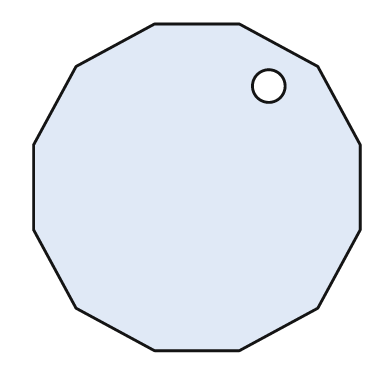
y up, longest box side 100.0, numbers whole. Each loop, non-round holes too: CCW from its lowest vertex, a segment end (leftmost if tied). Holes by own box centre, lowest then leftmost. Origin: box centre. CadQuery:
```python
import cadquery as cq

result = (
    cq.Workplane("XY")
    .moveTo(-13.0, -50.0)
    .lineTo(13.0, -50.0)
    .lineTo(37.0, -37.0)
    .lineTo(50.0, -13.0)
    .lineTo(50.0, 13.0)
    .lineTo(37.0, 37.0)
    .lineTo(13.0, 50.0)
    .lineTo(-13.0, 50.0)
    .lineTo(-37.0, 37.0)
    .lineTo(-50.0, 13.0)
    .lineTo(-50.0, -13.0)
    .lineTo(-37.0, -37.0)
    .close()
    .moveTo(22.0, 31.0)
    .circle(5.0)
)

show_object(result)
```